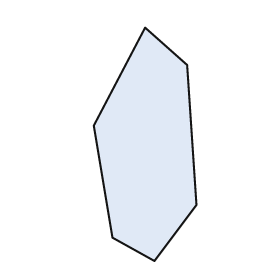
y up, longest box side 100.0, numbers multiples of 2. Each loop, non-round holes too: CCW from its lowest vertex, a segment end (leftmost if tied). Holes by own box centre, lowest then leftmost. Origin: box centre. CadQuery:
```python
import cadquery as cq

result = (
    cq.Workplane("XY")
    .moveTo(4.0, -50.0)
    .lineTo(22.0, -26.0)
    .lineTo(18.0, 34.0)
    .lineTo(0.0, 50.0)
    .lineTo(-22.0, 8.0)
    .lineTo(-14.0, -40.0)
    .close()
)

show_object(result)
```